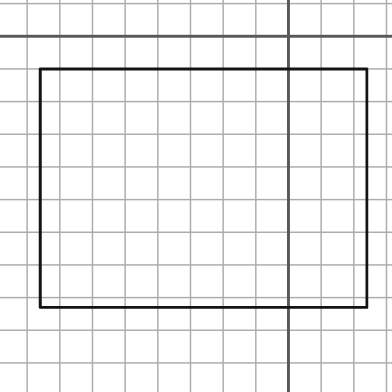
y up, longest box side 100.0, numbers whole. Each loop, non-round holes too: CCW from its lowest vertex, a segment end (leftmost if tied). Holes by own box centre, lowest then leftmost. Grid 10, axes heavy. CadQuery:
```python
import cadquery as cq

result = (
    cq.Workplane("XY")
    .moveTo(-76.0, -83.0)
    .lineTo(24.0, -83.0)
    .lineTo(24.0, -10.0)
    .lineTo(-76.0, -10.0)
    .close()
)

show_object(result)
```